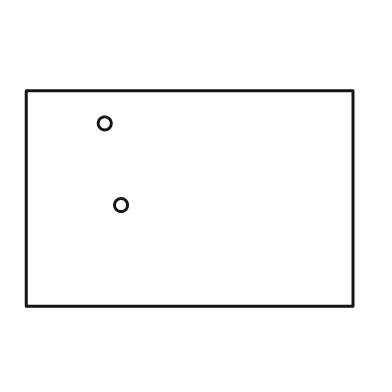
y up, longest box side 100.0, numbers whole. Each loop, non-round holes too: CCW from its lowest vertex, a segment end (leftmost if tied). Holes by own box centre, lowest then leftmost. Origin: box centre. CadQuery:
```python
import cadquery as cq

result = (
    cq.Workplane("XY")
    .moveTo(-50.0, -33.0)
    .lineTo(50.0, -33.0)
    .lineTo(50.0, 33.0)
    .lineTo(-50.0, 33.0)
    .close()
    .moveTo(-21.0, -2.0)
    .circle(2.0)
    .moveTo(-26.0, 23.0)
    .circle(2.0)
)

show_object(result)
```